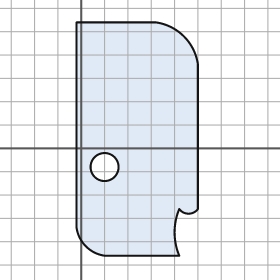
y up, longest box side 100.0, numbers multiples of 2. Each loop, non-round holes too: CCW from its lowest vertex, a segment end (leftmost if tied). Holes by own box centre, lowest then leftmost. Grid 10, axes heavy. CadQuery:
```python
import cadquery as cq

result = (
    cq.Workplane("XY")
    .moveTo(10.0, -46.0)
    .lineTo(42.0, -46.0)
    .threePointArc((40.0, -36.0), (42.0, -26.0))
    .threePointArc((46.0, -28.0), (50.0, -26.0))
    .lineTo(50.0, 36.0)
    .threePointArc((44.0, 48.0), (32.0, 54.0))
    .lineTo(-2.0, 54.0)
    .lineTo(-2.0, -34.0)
    .threePointArc((2.0, -42.0), (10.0, -46.0))
    .close()
    .moveTo(10.0, -8.0)
    .circle(6.0)
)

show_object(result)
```